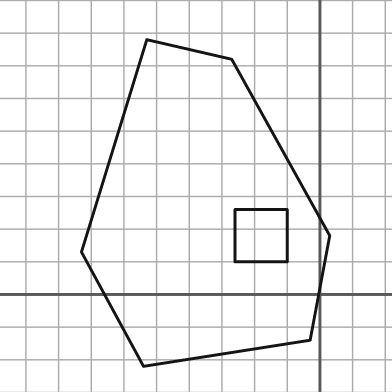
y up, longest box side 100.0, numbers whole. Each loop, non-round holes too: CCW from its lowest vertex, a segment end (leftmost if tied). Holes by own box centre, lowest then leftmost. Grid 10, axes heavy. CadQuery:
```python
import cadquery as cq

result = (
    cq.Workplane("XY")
    .moveTo(-54.0, -22.0)
    .lineTo(-3.0, -14.0)
    .lineTo(3.0, 18.0)
    .lineTo(-27.0, 72.0)
    .lineTo(-53.0, 78.0)
    .lineTo(-73.0, 13.0)
    .close()
    .moveTo(-26.0, 10.0)
    .lineTo(-10.0, 10.0)
    .lineTo(-10.0, 26.0)
    .lineTo(-26.0, 26.0)
    .close()
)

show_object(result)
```